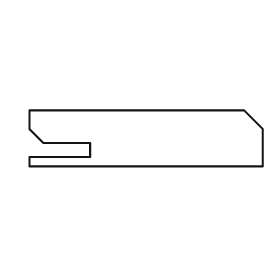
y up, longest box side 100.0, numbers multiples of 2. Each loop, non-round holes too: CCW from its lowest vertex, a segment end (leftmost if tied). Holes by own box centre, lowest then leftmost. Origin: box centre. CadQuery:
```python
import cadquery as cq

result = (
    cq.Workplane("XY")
    .moveTo(-50.0, -12.0)
    .lineTo(50.0, -12.0)
    .lineTo(50.0, 4.0)
    .lineTo(42.0, 12.0)
    .lineTo(-50.0, 12.0)
    .lineTo(-50.0, 4.0)
    .lineTo(-44.0, -2.0)
    .lineTo(-24.0, -2.0)
    .lineTo(-24.0, -8.0)
    .lineTo(-50.0, -8.0)
    .close()
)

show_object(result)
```